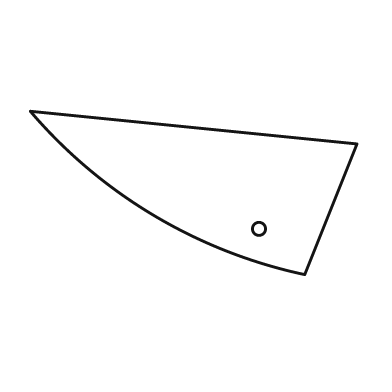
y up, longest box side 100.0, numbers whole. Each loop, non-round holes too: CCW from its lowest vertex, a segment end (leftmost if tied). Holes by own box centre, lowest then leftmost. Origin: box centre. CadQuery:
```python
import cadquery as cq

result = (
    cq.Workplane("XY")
    .moveTo(34.0, -25.0)
    .lineTo(50.0, 15.0)
    .lineTo(-50.0, 25.0)
    .threePointArc((-12.0, -7.0), (34.0, -25.0))
    .close()
    .moveTo(20.0, -11.0)
    .circle(2.0)
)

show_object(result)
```